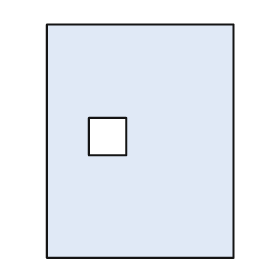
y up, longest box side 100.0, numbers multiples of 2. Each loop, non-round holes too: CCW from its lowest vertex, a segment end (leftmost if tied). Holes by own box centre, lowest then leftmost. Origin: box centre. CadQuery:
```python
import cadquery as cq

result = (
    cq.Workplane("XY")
    .moveTo(-40.0, -50.0)
    .lineTo(40.0, -50.0)
    .lineTo(40.0, 50.0)
    .lineTo(-40.0, 50.0)
    .close()
    .moveTo(-22.0, -6.0)
    .lineTo(-6.0, -6.0)
    .lineTo(-6.0, 10.0)
    .lineTo(-22.0, 10.0)
    .close()
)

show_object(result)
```